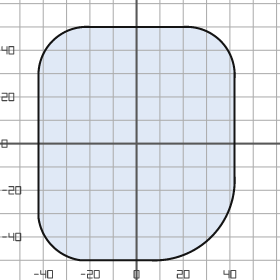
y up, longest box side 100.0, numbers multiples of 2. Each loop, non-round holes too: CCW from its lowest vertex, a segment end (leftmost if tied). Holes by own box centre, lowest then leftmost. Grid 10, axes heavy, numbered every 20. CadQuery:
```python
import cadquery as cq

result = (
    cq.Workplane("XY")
    .moveTo(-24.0, -50.0)
    .lineTo(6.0, -50.0)
    .threePointArc((32.0, -40.0), (42.0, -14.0))
    .lineTo(42.0, 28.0)
    .threePointArc((36.0, 44.0), (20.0, 50.0))
    .lineTo(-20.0, 50.0)
    .threePointArc((-36.0, 44.0), (-42.0, 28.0))
    .lineTo(-42.0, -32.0)
    .threePointArc((-36.0, -44.0), (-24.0, -50.0))
    .close()
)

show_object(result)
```